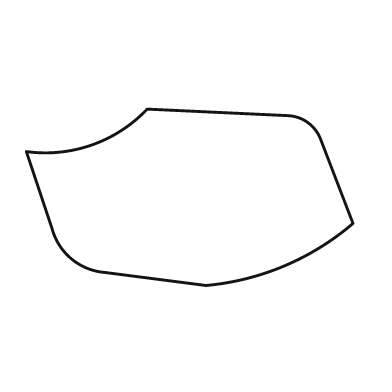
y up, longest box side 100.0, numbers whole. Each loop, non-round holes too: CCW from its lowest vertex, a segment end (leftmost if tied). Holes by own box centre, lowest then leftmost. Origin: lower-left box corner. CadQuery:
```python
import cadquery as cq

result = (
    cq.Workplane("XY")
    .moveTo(55.0, 0.0)
    .threePointArc((79.0, 6.0), (100.0, 19.0))
    .lineTo(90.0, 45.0)
    .threePointArc((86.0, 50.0), (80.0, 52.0))
    .lineTo(37.0, 54.0)
    .threePointArc((20.0, 43.0), (0.0, 41.0))
    .lineTo(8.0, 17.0)
    .threePointArc((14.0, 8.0), (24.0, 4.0))
    .close()
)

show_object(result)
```